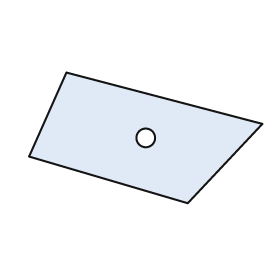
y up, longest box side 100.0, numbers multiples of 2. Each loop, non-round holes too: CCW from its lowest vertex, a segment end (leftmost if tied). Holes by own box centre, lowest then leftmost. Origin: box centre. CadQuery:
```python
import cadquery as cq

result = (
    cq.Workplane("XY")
    .moveTo(18.0, -28.0)
    .lineTo(50.0, 6.0)
    .lineTo(-34.0, 28.0)
    .lineTo(-50.0, -8.0)
    .close()
    .moveTo(0.0, 0.0)
    .circle(4.0)
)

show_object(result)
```